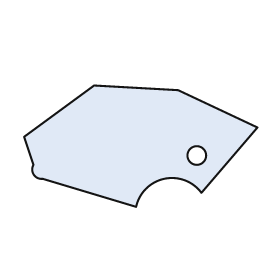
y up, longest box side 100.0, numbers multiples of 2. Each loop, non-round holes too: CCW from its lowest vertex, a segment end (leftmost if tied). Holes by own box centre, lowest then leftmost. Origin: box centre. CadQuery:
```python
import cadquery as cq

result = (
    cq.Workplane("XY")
    .moveTo(-2.0, -26.0)
    .threePointArc((10.0, -14.0), (26.0, -20.0))
    .lineTo(50.0, 8.0)
    .lineTo(16.0, 24.0)
    .lineTo(-20.0, 26.0)
    .lineTo(-50.0, 4.0)
    .lineTo(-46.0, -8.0)
    .threePointArc((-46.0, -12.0), (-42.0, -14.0))
    .close()
    .moveTo(24.0, -4.0)
    .circle(4.0)
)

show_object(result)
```